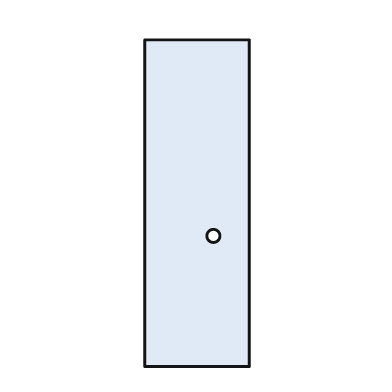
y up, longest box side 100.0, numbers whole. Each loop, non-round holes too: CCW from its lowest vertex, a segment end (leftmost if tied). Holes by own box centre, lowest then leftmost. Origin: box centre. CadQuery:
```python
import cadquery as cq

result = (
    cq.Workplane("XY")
    .moveTo(-16.0, -50.0)
    .lineTo(16.0, -50.0)
    .lineTo(16.0, 50.0)
    .lineTo(-16.0, 50.0)
    .close()
    .moveTo(5.0, -10.0)
    .circle(2.0)
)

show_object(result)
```